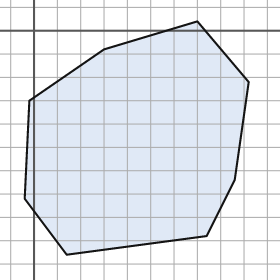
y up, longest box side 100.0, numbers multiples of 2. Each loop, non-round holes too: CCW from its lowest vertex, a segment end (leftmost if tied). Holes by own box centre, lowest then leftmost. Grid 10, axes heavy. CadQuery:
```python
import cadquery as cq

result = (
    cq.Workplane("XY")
    .moveTo(14.0, -96.0)
    .lineTo(74.0, -88.0)
    .lineTo(86.0, -64.0)
    .lineTo(92.0, -22.0)
    .lineTo(70.0, 4.0)
    .lineTo(30.0, -8.0)
    .lineTo(-2.0, -30.0)
    .lineTo(-4.0, -72.0)
    .close()
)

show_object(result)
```